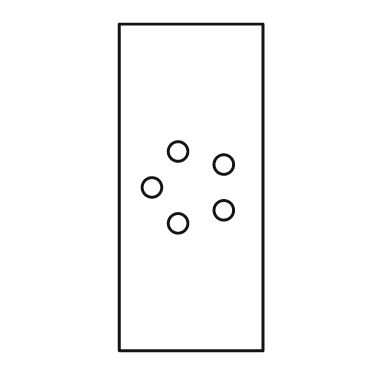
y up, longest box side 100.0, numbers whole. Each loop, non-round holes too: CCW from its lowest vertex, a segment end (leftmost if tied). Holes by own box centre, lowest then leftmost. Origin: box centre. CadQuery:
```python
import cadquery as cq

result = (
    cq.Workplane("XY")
    .moveTo(-22.0, -50.0)
    .lineTo(22.0, -50.0)
    .lineTo(22.0, 50.0)
    .lineTo(-22.0, 50.0)
    .close()
    .moveTo(-4.0, -11.0)
    .circle(3.0)
    .moveTo(10.0, -7.0)
    .circle(3.0)
    .moveTo(-12.0, 0.0)
    .circle(3.0)
    .moveTo(10.0, 7.0)
    .circle(3.0)
    .moveTo(-4.0, 11.0)
    .circle(3.0)
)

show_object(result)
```